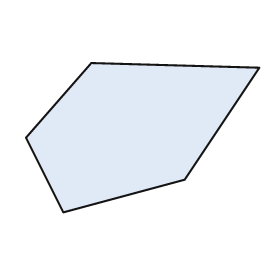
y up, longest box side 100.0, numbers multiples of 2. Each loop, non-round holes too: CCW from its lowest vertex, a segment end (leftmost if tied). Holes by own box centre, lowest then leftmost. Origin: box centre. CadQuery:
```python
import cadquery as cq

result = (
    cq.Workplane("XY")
    .moveTo(-34.0, -32.0)
    .lineTo(18.0, -18.0)
    .lineTo(50.0, 30.0)
    .lineTo(-22.0, 32.0)
    .lineTo(-50.0, 0.0)
    .close()
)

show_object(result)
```